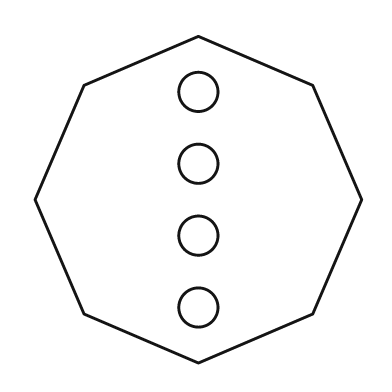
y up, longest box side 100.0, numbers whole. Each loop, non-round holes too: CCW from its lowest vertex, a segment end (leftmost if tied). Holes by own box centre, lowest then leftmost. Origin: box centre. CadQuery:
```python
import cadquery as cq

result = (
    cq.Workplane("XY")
    .moveTo(0.0, -50.0)
    .lineTo(35.0, -35.0)
    .lineTo(50.0, 0.0)
    .lineTo(35.0, 35.0)
    .lineTo(0.0, 50.0)
    .lineTo(-35.0, 35.0)
    .lineTo(-50.0, 0.0)
    .lineTo(-35.0, -35.0)
    .close()
    .moveTo(0.0, -33.0)
    .circle(6.0)
    .moveTo(0.0, -11.0)
    .circle(6.0)
    .moveTo(0.0, 11.0)
    .circle(6.0)
    .moveTo(0.0, 33.0)
    .circle(6.0)
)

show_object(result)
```